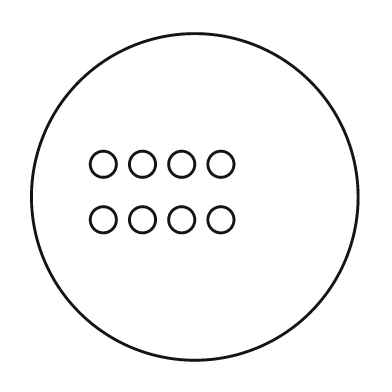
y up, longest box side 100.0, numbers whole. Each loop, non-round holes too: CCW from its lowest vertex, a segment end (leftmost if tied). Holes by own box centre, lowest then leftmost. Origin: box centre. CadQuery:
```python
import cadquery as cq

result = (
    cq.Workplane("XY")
    .moveTo(0.0, 0.0)
    .circle(50.0)
    .moveTo(-28.0, -7.0)
    .circle(4.0)
    .moveTo(-16.0, -7.0)
    .circle(4.0)
    .moveTo(-4.0, -7.0)
    .circle(4.0)
    .moveTo(8.0, -7.0)
    .circle(4.0)
    .moveTo(-28.0, 10.0)
    .circle(4.0)
    .moveTo(-16.0, 10.0)
    .circle(4.0)
    .moveTo(-4.0, 10.0)
    .circle(4.0)
    .moveTo(8.0, 10.0)
    .circle(4.0)
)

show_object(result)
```